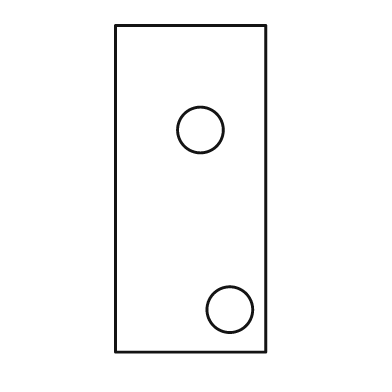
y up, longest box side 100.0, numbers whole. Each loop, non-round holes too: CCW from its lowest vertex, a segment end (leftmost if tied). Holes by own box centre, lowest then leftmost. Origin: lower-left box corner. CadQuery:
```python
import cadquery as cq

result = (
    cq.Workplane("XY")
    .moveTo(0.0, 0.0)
    .lineTo(46.0, 0.0)
    .lineTo(46.0, 100.0)
    .lineTo(0.0, 100.0)
    .close()
    .moveTo(35.0, 13.0)
    .circle(7.0)
    .moveTo(26.0, 68.0)
    .circle(7.0)
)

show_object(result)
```